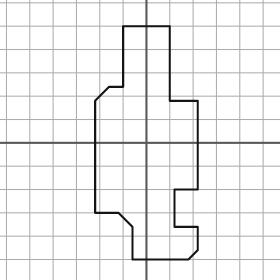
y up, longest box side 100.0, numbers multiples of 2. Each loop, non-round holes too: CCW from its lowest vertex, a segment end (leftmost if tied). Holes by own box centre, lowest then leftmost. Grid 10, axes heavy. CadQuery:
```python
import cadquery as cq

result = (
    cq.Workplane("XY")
    .moveTo(-6.0, -50.0)
    .lineTo(18.0, -50.0)
    .lineTo(22.0, -46.0)
    .lineTo(22.0, -36.0)
    .lineTo(12.0, -36.0)
    .lineTo(12.0, -20.0)
    .lineTo(22.0, -20.0)
    .lineTo(22.0, 18.0)
    .lineTo(10.0, 18.0)
    .lineTo(10.0, 50.0)
    .lineTo(-10.0, 50.0)
    .lineTo(-10.0, 24.0)
    .lineTo(-16.0, 24.0)
    .lineTo(-22.0, 18.0)
    .lineTo(-22.0, -30.0)
    .lineTo(-12.0, -30.0)
    .lineTo(-6.0, -36.0)
    .close()
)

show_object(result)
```